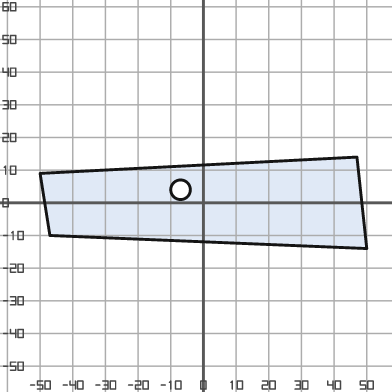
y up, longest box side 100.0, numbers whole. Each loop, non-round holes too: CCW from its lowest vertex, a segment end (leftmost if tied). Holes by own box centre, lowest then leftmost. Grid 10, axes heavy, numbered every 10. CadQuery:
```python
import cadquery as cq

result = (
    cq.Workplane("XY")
    .moveTo(50.0, -14.0)
    .lineTo(47.0, 14.0)
    .lineTo(-50.0, 9.0)
    .lineTo(-47.0, -10.0)
    .close()
    .moveTo(-7.0, 4.0)
    .circle(3.0)
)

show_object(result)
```